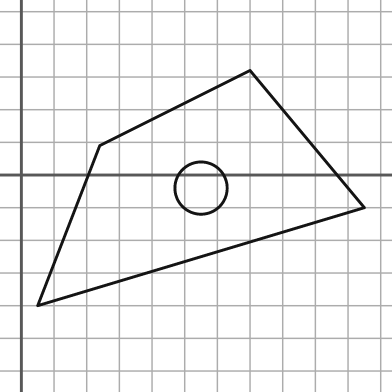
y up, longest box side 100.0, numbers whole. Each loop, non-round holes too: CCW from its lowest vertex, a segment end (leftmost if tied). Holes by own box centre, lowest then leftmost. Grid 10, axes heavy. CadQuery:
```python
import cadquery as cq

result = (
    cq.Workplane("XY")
    .moveTo(5.0, -40.0)
    .lineTo(105.0, -10.0)
    .lineTo(70.0, 32.0)
    .lineTo(24.0, 9.0)
    .close()
    .moveTo(55.0, -4.0)
    .circle(8.0)
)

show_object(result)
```